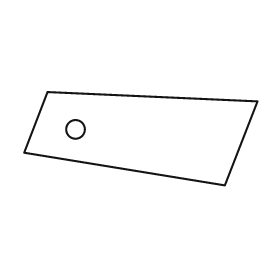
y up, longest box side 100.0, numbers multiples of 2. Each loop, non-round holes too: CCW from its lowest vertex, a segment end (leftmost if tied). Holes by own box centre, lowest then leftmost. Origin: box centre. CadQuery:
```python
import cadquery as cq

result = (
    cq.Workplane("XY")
    .moveTo(36.0, -20.0)
    .lineTo(50.0, 16.0)
    .lineTo(-40.0, 20.0)
    .lineTo(-50.0, -6.0)
    .close()
    .moveTo(-28.0, 4.0)
    .circle(4.0)
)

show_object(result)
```